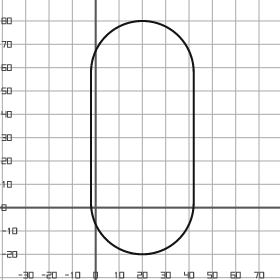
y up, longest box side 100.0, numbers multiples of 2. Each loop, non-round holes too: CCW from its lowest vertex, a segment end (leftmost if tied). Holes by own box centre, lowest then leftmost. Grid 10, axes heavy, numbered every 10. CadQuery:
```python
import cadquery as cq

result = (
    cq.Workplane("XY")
    .moveTo(-2.0, 2.0)
    .threePointArc((20.0, -20.0), (42.0, 2.0))
    .lineTo(42.0, 58.0)
    .threePointArc((20.0, 80.0), (-2.0, 58.0))
    .close()
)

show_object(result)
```